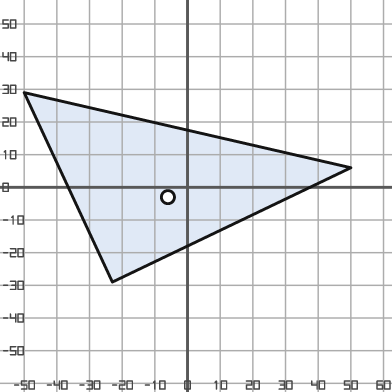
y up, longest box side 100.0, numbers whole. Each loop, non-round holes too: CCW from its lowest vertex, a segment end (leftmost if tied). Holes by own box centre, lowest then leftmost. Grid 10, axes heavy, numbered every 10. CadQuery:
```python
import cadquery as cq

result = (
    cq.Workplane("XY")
    .moveTo(-23.0, -29.0)
    .lineTo(50.0, 6.0)
    .lineTo(-50.0, 29.0)
    .close()
    .moveTo(-6.0, -3.0)
    .circle(2.0)
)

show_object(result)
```